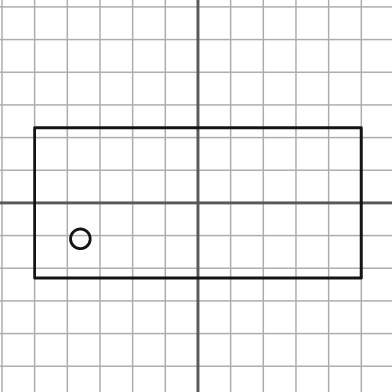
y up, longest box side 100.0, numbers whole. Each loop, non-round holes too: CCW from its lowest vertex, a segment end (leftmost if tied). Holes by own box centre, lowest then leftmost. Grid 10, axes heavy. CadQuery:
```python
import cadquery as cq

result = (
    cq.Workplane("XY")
    .moveTo(-50.0, -23.0)
    .lineTo(50.0, -23.0)
    .lineTo(50.0, 23.0)
    .lineTo(-50.0, 23.0)
    .close()
    .moveTo(-36.0, -11.0)
    .circle(3.0)
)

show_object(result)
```